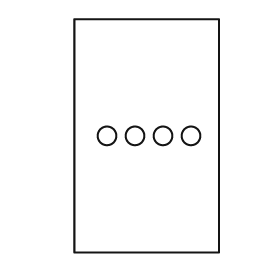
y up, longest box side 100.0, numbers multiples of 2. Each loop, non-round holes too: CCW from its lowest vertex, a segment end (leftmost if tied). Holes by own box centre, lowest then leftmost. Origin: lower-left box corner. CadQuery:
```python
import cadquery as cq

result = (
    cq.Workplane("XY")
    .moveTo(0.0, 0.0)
    .lineTo(62.0, 0.0)
    .lineTo(62.0, 100.0)
    .lineTo(0.0, 100.0)
    .close()
    .moveTo(14.0, 50.0)
    .circle(4.0)
    .moveTo(26.0, 50.0)
    .circle(4.0)
    .moveTo(38.0, 50.0)
    .circle(4.0)
    .moveTo(50.0, 50.0)
    .circle(4.0)
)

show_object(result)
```